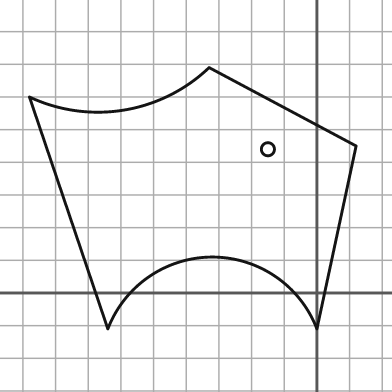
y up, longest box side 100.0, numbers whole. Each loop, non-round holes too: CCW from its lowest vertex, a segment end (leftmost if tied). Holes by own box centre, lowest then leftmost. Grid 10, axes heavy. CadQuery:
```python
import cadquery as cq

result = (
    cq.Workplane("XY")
    .moveTo(-64.0, -11.0)
    .threePointArc((-32.0, 11.0), (0.0, -11.0))
    .lineTo(12.0, 45.0)
    .lineTo(-33.0, 69.0)
    .threePointArc((-59.0, 56.0), (-88.0, 60.0))
    .close()
    .moveTo(-15.0, 44.0)
    .circle(2.0)
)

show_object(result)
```